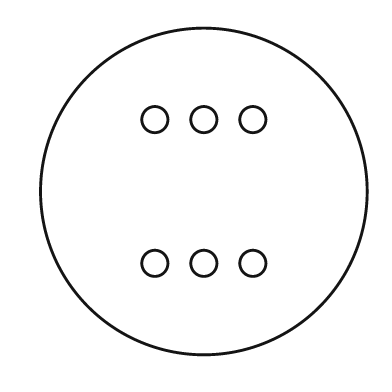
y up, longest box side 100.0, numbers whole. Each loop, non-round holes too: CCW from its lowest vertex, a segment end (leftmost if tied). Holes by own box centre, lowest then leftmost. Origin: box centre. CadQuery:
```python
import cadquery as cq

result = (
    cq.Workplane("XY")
    .moveTo(0.0, 0.0)
    .circle(50.0)
    .moveTo(-15.0, -22.0)
    .circle(4.0)
    .moveTo(0.0, -22.0)
    .circle(4.0)
    .moveTo(15.0, -22.0)
    .circle(4.0)
    .moveTo(-15.0, 22.0)
    .circle(4.0)
    .moveTo(0.0, 22.0)
    .circle(4.0)
    .moveTo(15.0, 22.0)
    .circle(4.0)
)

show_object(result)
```